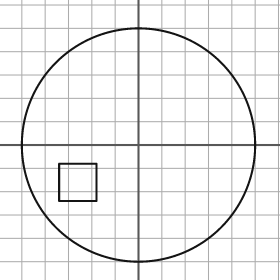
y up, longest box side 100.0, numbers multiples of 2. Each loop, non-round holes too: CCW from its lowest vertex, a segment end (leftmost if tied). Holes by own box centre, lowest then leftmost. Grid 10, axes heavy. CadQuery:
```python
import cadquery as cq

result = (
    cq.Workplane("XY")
    .moveTo(0.0, 0.0)
    .circle(50.0)
    .moveTo(-34.0, -24.0)
    .lineTo(-18.0, -24.0)
    .lineTo(-18.0, -8.0)
    .lineTo(-34.0, -8.0)
    .close()
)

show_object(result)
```